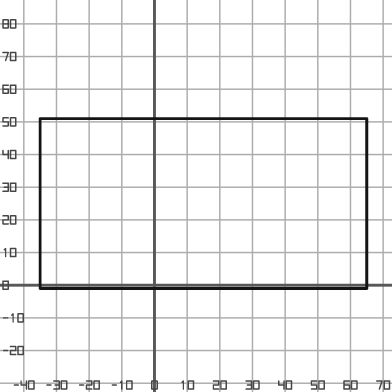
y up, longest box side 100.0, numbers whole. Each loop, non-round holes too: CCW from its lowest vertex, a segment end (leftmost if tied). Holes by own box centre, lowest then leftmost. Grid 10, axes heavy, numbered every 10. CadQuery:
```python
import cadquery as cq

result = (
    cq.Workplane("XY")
    .moveTo(-35.0, -1.0)
    .lineTo(65.0, -1.0)
    .lineTo(65.0, 51.0)
    .lineTo(-35.0, 51.0)
    .close()
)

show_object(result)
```